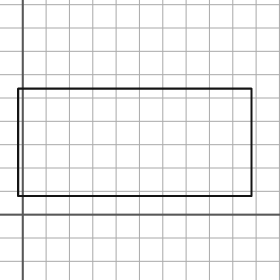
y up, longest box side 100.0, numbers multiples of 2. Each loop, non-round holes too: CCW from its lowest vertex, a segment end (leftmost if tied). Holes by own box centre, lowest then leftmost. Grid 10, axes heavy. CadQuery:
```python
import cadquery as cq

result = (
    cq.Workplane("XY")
    .moveTo(-2.0, 8.0)
    .lineTo(98.0, 8.0)
    .lineTo(98.0, 54.0)
    .lineTo(-2.0, 54.0)
    .close()
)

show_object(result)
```